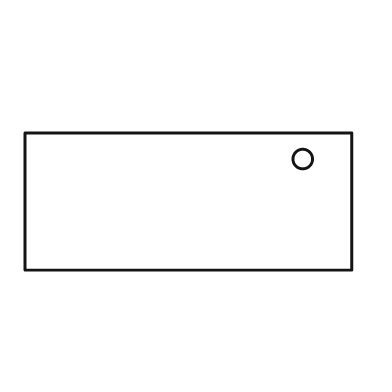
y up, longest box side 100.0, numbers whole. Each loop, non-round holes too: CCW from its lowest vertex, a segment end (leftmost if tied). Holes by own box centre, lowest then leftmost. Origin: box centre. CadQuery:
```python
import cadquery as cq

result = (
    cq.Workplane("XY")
    .moveTo(-50.0, -21.0)
    .lineTo(50.0, -21.0)
    .lineTo(50.0, 21.0)
    .lineTo(-50.0, 21.0)
    .close()
    .moveTo(35.0, 13.0)
    .circle(3.0)
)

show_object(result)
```